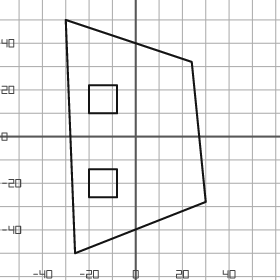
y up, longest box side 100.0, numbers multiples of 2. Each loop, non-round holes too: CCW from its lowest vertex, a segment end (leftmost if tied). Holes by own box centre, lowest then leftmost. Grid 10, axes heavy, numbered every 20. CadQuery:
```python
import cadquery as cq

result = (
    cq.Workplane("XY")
    .moveTo(-26.0, -50.0)
    .lineTo(30.0, -28.0)
    .lineTo(24.0, 32.0)
    .lineTo(-30.0, 50.0)
    .close()
    .moveTo(-20.0, -26.0)
    .lineTo(-8.0, -26.0)
    .lineTo(-8.0, -14.0)
    .lineTo(-20.0, -14.0)
    .close()
    .moveTo(-20.0, 10.0)
    .lineTo(-8.0, 10.0)
    .lineTo(-8.0, 22.0)
    .lineTo(-20.0, 22.0)
    .close()
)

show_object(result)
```